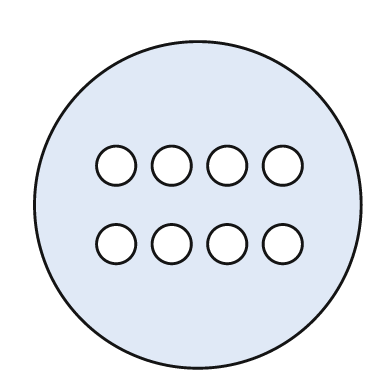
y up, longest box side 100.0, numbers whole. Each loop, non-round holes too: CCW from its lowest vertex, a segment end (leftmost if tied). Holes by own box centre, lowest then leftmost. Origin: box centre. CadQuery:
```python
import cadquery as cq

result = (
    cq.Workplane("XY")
    .moveTo(0.0, 0.0)
    .circle(50.0)
    .moveTo(-25.0, -12.0)
    .circle(6.0)
    .moveTo(-8.0, -12.0)
    .circle(6.0)
    .moveTo(9.0, -12.0)
    .circle(6.0)
    .moveTo(26.0, -12.0)
    .circle(6.0)
    .moveTo(-25.0, 12.0)
    .circle(6.0)
    .moveTo(-8.0, 12.0)
    .circle(6.0)
    .moveTo(9.0, 12.0)
    .circle(6.0)
    .moveTo(26.0, 12.0)
    .circle(6.0)
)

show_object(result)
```